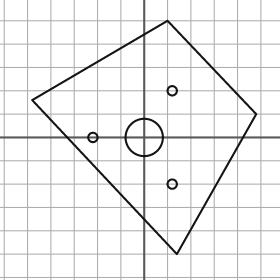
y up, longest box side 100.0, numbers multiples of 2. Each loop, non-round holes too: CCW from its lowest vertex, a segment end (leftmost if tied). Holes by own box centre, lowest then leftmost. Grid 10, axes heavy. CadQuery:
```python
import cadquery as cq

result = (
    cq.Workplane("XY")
    .moveTo(14.0, -50.0)
    .lineTo(48.0, 10.0)
    .lineTo(10.0, 50.0)
    .lineTo(-48.0, 16.0)
    .close()
    .moveTo(12.0, -20.0)
    .circle(2.0)
    .moveTo(-22.0, 0.0)
    .circle(2.0)
    .moveTo(0.0, 0.0)
    .circle(8.0)
    .moveTo(12.0, 20.0)
    .circle(2.0)
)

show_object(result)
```